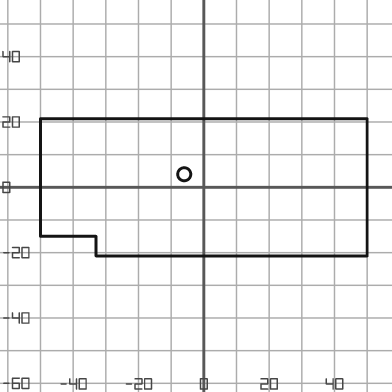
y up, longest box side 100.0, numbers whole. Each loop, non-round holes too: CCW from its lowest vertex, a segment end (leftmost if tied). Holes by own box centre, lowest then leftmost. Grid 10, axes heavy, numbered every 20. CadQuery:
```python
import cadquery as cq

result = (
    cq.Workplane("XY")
    .moveTo(-33.0, -21.0)
    .lineTo(50.0, -21.0)
    .lineTo(50.0, 21.0)
    .lineTo(-50.0, 21.0)
    .lineTo(-50.0, -15.0)
    .lineTo(-33.0, -15.0)
    .close()
    .moveTo(-6.0, 4.0)
    .circle(2.0)
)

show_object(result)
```